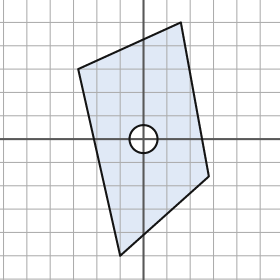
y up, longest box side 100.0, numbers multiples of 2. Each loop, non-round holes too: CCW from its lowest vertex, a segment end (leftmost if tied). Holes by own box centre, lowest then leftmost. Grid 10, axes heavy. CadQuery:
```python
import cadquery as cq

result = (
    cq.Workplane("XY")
    .moveTo(-10.0, -50.0)
    .lineTo(28.0, -16.0)
    .lineTo(16.0, 50.0)
    .lineTo(-28.0, 30.0)
    .close()
    .moveTo(0.0, 0.0)
    .circle(6.0)
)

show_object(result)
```